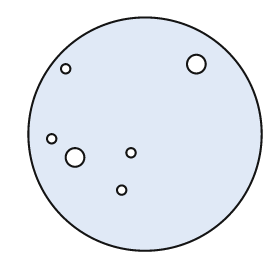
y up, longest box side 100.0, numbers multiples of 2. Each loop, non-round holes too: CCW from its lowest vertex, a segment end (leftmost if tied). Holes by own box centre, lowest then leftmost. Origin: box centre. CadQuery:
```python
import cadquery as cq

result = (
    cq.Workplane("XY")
    .moveTo(0.0, 0.0)
    .circle(50.0)
    .moveTo(-10.0, -24.0)
    .circle(2.0)
    .moveTo(-30.0, -10.0)
    .circle(4.0)
    .moveTo(-6.0, -8.0)
    .circle(2.0)
    .moveTo(-40.0, -2.0)
    .circle(2.0)
    .moveTo(-34.0, 28.0)
    .circle(2.0)
    .moveTo(22.0, 30.0)
    .circle(4.0)
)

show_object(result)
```